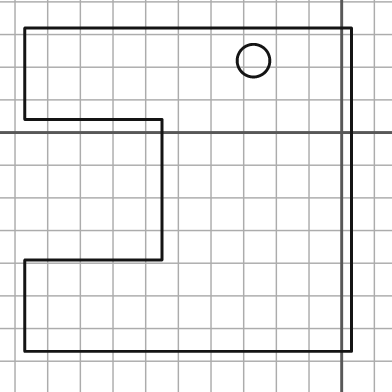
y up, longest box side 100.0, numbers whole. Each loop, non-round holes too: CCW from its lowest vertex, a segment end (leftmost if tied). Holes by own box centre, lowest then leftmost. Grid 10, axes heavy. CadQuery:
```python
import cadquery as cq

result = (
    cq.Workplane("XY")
    .moveTo(-97.0, -67.0)
    .lineTo(3.0, -67.0)
    .lineTo(3.0, 32.0)
    .lineTo(-97.0, 32.0)
    .lineTo(-97.0, 4.0)
    .lineTo(-55.0, 4.0)
    .lineTo(-55.0, -39.0)
    .lineTo(-97.0, -39.0)
    .close()
    .moveTo(-27.0, 22.0)
    .circle(5.0)
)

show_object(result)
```